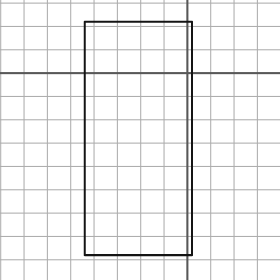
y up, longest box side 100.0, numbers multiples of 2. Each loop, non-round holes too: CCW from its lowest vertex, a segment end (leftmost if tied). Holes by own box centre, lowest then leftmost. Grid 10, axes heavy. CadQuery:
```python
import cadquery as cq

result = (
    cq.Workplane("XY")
    .moveTo(-44.0, -78.0)
    .lineTo(2.0, -78.0)
    .lineTo(2.0, 22.0)
    .lineTo(-44.0, 22.0)
    .close()
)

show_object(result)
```